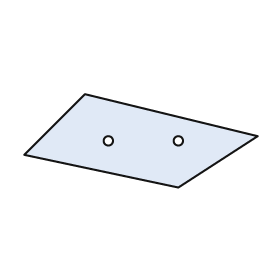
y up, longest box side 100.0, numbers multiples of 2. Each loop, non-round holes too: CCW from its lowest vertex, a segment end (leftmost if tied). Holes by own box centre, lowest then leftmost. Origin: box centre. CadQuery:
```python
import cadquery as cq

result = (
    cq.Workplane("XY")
    .moveTo(16.0, -20.0)
    .lineTo(50.0, 2.0)
    .lineTo(-24.0, 20.0)
    .lineTo(-50.0, -6.0)
    .close()
    .moveTo(-14.0, 0.0)
    .circle(2.0)
    .moveTo(16.0, 0.0)
    .circle(2.0)
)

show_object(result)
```